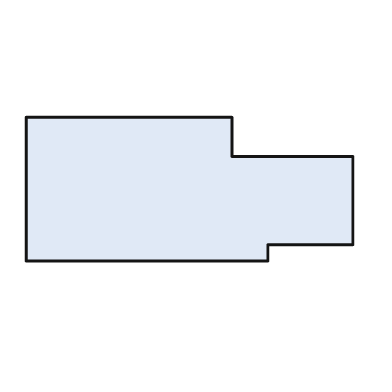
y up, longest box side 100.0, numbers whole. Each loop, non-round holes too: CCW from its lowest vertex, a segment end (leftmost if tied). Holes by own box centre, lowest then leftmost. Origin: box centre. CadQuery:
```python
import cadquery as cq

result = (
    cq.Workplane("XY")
    .moveTo(-50.0, -22.0)
    .lineTo(24.0, -22.0)
    .lineTo(24.0, -17.0)
    .lineTo(50.0, -17.0)
    .lineTo(50.0, 10.0)
    .lineTo(13.0, 10.0)
    .lineTo(13.0, 22.0)
    .lineTo(-50.0, 22.0)
    .close()
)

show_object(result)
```